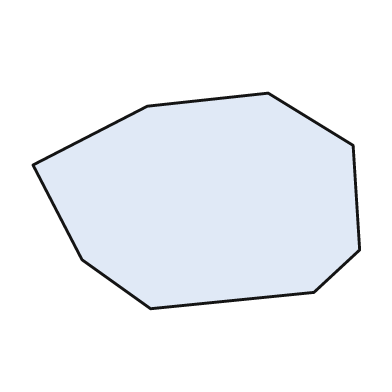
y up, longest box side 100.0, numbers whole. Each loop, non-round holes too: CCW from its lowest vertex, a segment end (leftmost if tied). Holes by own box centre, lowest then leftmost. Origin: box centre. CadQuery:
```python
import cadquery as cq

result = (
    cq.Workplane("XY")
    .moveTo(-14.0, -33.0)
    .lineTo(36.0, -28.0)
    .lineTo(50.0, -15.0)
    .lineTo(48.0, 17.0)
    .lineTo(22.0, 33.0)
    .lineTo(-15.0, 29.0)
    .lineTo(-50.0, 11.0)
    .lineTo(-35.0, -18.0)
    .close()
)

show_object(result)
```